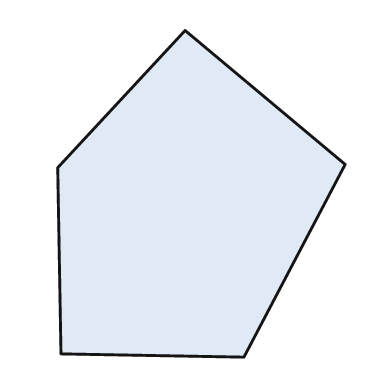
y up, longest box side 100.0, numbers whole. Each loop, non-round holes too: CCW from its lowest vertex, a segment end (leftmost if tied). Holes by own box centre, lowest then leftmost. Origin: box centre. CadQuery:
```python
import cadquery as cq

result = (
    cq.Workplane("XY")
    .moveTo(13.0, -50.0)
    .lineTo(44.0, 9.0)
    .lineTo(-5.0, 50.0)
    .lineTo(-44.0, 8.0)
    .lineTo(-43.0, -49.0)
    .close()
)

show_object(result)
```